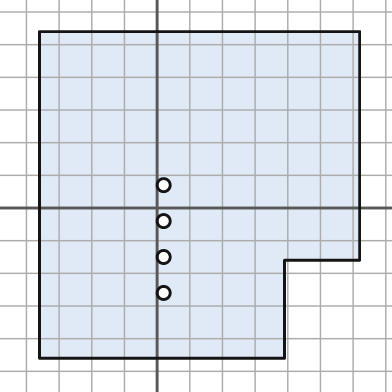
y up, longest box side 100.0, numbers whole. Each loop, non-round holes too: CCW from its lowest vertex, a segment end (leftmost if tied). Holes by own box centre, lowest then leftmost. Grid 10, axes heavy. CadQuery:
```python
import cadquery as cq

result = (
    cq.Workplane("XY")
    .moveTo(-36.0, -46.0)
    .lineTo(39.0, -46.0)
    .lineTo(39.0, -16.0)
    .lineTo(62.0, -16.0)
    .lineTo(62.0, 54.0)
    .lineTo(-36.0, 54.0)
    .close()
    .moveTo(2.0, -26.0)
    .circle(2.0)
    .moveTo(2.0, -15.0)
    .circle(2.0)
    .moveTo(2.0, -4.0)
    .circle(2.0)
    .moveTo(2.0, 7.0)
    .circle(2.0)
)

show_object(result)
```